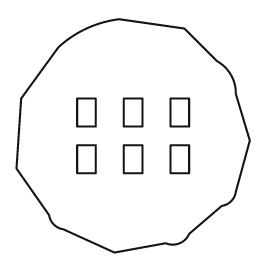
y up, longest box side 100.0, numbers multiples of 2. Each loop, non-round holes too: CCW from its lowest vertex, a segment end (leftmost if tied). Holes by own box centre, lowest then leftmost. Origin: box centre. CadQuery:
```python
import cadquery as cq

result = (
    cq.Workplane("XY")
    .moveTo(-8.0, -50.0)
    .lineTo(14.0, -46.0)
    .threePointArc((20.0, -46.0), (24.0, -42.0))
    .lineTo(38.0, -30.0)
    .threePointArc((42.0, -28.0), (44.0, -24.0))
    .lineTo(50.0, -2.0)
    .lineTo(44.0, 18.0)
    .threePointArc((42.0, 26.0), (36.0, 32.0))
    .lineTo(22.0, 46.0)
    .lineTo(-6.0, 50.0)
    .threePointArc((-20.0, 46.0), (-32.0, 38.0))
    .lineTo(-48.0, 16.0)
    .lineTo(-50.0, -14.0)
    .lineTo(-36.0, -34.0)
    .threePointArc((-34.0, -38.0), (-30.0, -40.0))
    .close()
    .moveTo(-24.0, -16.0)
    .lineTo(-16.0, -16.0)
    .lineTo(-16.0, -4.0)
    .lineTo(-24.0, -4.0)
    .close()
    .moveTo(-4.0, -16.0)
    .lineTo(4.0, -16.0)
    .lineTo(4.0, -4.0)
    .lineTo(-4.0, -4.0)
    .close()
    .moveTo(16.0, -16.0)
    .lineTo(24.0, -16.0)
    .lineTo(24.0, -4.0)
    .lineTo(16.0, -4.0)
    .close()
    .moveTo(-24.0, 4.0)
    .lineTo(-16.0, 4.0)
    .lineTo(-16.0, 16.0)
    .lineTo(-24.0, 16.0)
    .close()
    .moveTo(-4.0, 4.0)
    .lineTo(4.0, 4.0)
    .lineTo(4.0, 16.0)
    .lineTo(-4.0, 16.0)
    .close()
    .moveTo(16.0, 4.0)
    .lineTo(24.0, 4.0)
    .lineTo(24.0, 16.0)
    .lineTo(16.0, 16.0)
    .close()
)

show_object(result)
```